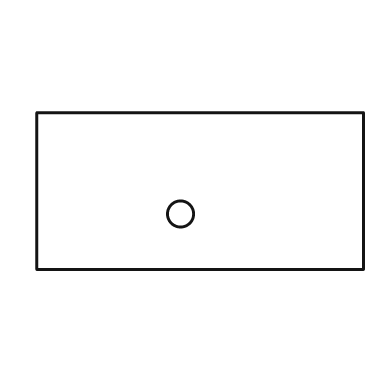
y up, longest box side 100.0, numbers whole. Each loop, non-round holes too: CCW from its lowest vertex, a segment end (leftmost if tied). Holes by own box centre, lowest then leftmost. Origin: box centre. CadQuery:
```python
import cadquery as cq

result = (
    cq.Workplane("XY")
    .moveTo(-50.0, -24.0)
    .lineTo(50.0, -24.0)
    .lineTo(50.0, 24.0)
    .lineTo(-50.0, 24.0)
    .close()
    .moveTo(-6.0, -7.0)
    .circle(4.0)
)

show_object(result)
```